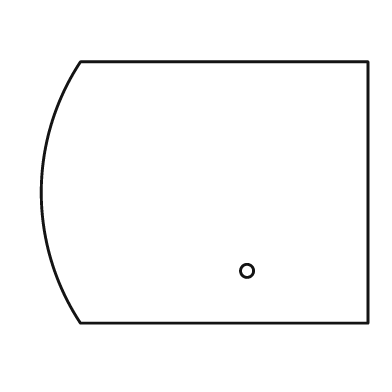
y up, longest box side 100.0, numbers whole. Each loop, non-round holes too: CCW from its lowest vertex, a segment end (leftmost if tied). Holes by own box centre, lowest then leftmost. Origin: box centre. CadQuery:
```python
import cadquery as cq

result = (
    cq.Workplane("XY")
    .moveTo(-38.0, -40.0)
    .lineTo(50.0, -40.0)
    .lineTo(50.0, 40.0)
    .lineTo(-38.0, 40.0)
    .threePointArc((-50.0, 0.0), (-38.0, -40.0))
    .close()
    .moveTo(13.0, -24.0)
    .circle(2.0)
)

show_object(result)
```